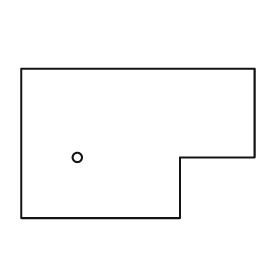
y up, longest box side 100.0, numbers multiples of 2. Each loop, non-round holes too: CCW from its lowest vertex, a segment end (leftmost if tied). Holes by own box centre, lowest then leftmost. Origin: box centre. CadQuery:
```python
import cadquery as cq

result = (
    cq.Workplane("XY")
    .moveTo(-50.0, -32.0)
    .lineTo(18.0, -32.0)
    .lineTo(18.0, -6.0)
    .lineTo(50.0, -6.0)
    .lineTo(50.0, 32.0)
    .lineTo(-50.0, 32.0)
    .close()
    .moveTo(-26.0, -6.0)
    .circle(2.0)
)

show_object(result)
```